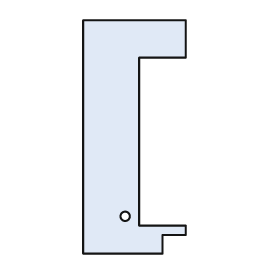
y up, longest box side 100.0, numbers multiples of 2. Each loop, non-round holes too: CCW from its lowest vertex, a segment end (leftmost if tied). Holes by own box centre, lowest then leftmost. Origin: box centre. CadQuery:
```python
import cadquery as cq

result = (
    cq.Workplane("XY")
    .moveTo(-22.0, -50.0)
    .lineTo(12.0, -50.0)
    .lineTo(12.0, -42.0)
    .lineTo(22.0, -42.0)
    .lineTo(22.0, -38.0)
    .lineTo(2.0, -38.0)
    .lineTo(2.0, 34.0)
    .lineTo(22.0, 34.0)
    .lineTo(22.0, 50.0)
    .lineTo(-22.0, 50.0)
    .close()
    .moveTo(-4.0, -34.0)
    .circle(2.0)
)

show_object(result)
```